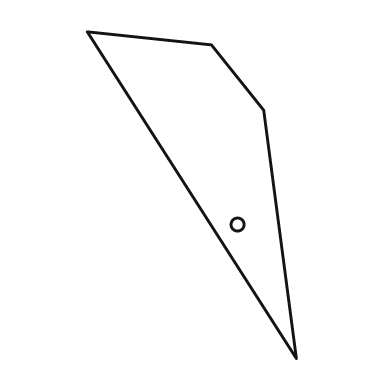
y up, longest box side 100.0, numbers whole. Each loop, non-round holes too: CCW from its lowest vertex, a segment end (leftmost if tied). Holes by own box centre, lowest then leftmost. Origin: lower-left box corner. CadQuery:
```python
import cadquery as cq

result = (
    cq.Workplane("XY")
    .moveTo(64.0, 0.0)
    .lineTo(54.0, 76.0)
    .lineTo(38.0, 96.0)
    .lineTo(0.0, 100.0)
    .close()
    .moveTo(46.0, 41.0)
    .circle(2.0)
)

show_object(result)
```